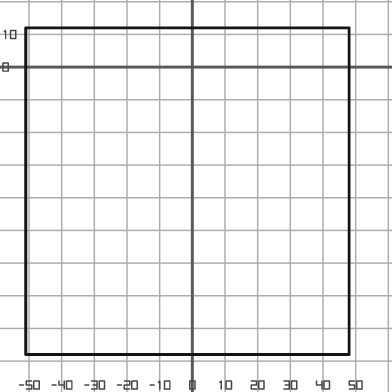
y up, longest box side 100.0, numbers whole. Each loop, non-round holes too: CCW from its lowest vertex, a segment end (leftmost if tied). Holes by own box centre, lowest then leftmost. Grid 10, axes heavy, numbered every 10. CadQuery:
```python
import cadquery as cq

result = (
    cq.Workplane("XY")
    .moveTo(-51.0, -88.0)
    .lineTo(48.0, -88.0)
    .lineTo(48.0, 12.0)
    .lineTo(-51.0, 12.0)
    .close()
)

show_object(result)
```